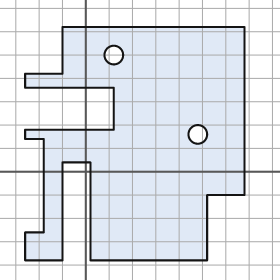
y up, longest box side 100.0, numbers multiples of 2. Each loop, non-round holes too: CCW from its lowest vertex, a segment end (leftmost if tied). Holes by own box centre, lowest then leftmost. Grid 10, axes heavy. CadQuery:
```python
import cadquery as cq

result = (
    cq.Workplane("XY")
    .moveTo(-26.0, -38.0)
    .lineTo(-10.0, -38.0)
    .lineTo(-10.0, 4.0)
    .lineTo(2.0, 4.0)
    .lineTo(2.0, -38.0)
    .lineTo(52.0, -38.0)
    .lineTo(52.0, -10.0)
    .lineTo(68.0, -10.0)
    .lineTo(68.0, 62.0)
    .lineTo(-10.0, 62.0)
    .lineTo(-10.0, 42.0)
    .lineTo(-26.0, 42.0)
    .lineTo(-26.0, 36.0)
    .lineTo(12.0, 36.0)
    .lineTo(12.0, 18.0)
    .lineTo(-26.0, 18.0)
    .lineTo(-26.0, 14.0)
    .lineTo(-18.0, 14.0)
    .lineTo(-18.0, -26.0)
    .lineTo(-26.0, -26.0)
    .close()
    .moveTo(48.0, 16.0)
    .circle(4.0)
    .moveTo(12.0, 50.0)
    .circle(4.0)
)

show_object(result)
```